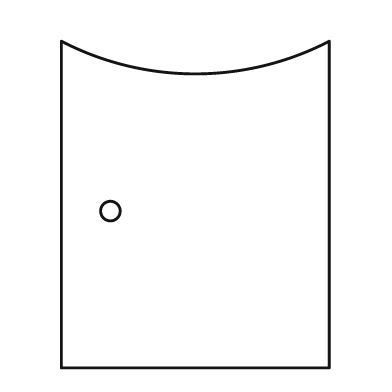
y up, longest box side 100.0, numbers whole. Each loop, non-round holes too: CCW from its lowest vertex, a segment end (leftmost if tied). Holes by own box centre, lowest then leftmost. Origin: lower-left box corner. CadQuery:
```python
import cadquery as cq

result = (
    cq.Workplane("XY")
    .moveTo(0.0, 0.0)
    .lineTo(82.0, 0.0)
    .lineTo(82.0, 100.0)
    .threePointArc((41.0, 90.0), (0.0, 100.0))
    .close()
    .moveTo(15.0, 48.0)
    .circle(3.0)
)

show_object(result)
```